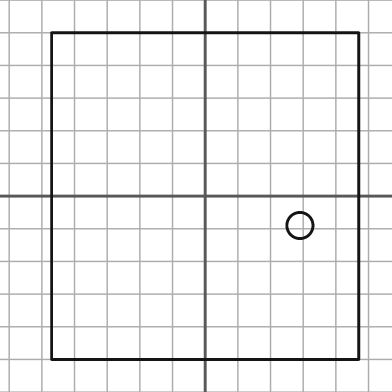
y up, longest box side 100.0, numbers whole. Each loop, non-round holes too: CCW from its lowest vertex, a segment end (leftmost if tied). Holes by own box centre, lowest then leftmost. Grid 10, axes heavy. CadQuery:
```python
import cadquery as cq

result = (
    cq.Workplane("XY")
    .moveTo(-47.0, -50.0)
    .lineTo(47.0, -50.0)
    .lineTo(47.0, 50.0)
    .lineTo(-47.0, 50.0)
    .close()
    .moveTo(29.0, -9.0)
    .circle(4.0)
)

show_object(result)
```